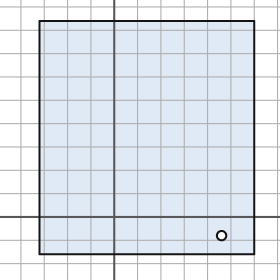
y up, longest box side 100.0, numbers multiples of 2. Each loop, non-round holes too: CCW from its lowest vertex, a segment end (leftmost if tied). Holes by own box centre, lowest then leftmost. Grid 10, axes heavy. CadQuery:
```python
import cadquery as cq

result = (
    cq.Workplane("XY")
    .moveTo(-32.0, -16.0)
    .lineTo(60.0, -16.0)
    .lineTo(60.0, 84.0)
    .lineTo(-32.0, 84.0)
    .close()
    .moveTo(46.0, -8.0)
    .circle(2.0)
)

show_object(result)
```